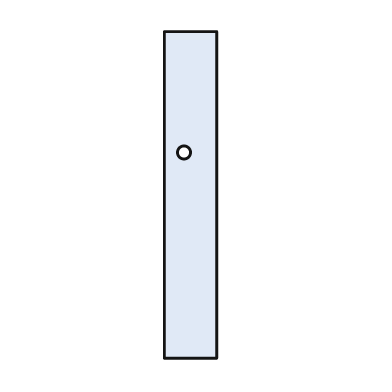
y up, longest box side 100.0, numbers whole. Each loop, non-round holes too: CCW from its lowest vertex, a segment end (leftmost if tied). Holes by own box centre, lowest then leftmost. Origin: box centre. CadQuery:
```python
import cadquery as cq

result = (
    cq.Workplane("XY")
    .moveTo(-8.0, -50.0)
    .lineTo(8.0, -50.0)
    .lineTo(8.0, 50.0)
    .lineTo(-8.0, 50.0)
    .close()
    .moveTo(-2.0, 13.0)
    .circle(2.0)
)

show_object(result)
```